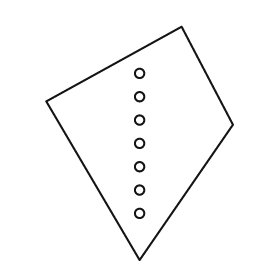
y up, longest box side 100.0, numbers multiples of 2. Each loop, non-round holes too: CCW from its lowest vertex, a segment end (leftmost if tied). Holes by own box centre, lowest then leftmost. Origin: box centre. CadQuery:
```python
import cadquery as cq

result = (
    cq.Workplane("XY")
    .moveTo(0.0, -50.0)
    .lineTo(40.0, 8.0)
    .lineTo(18.0, 50.0)
    .lineTo(-40.0, 18.0)
    .close()
    .moveTo(0.0, -30.0)
    .circle(2.0)
    .moveTo(0.0, -20.0)
    .circle(2.0)
    .moveTo(0.0, -10.0)
    .circle(2.0)
    .moveTo(0.0, 0.0)
    .circle(2.0)
    .moveTo(0.0, 10.0)
    .circle(2.0)
    .moveTo(0.0, 20.0)
    .circle(2.0)
    .moveTo(0.0, 30.0)
    .circle(2.0)
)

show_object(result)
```